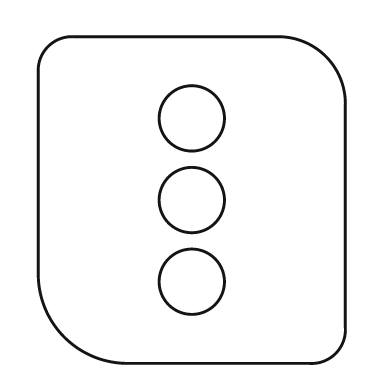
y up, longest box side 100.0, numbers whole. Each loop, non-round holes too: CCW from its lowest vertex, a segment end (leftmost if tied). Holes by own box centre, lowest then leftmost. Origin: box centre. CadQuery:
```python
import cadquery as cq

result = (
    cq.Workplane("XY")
    .moveTo(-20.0, -50.0)
    .lineTo(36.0, -50.0)
    .threePointArc((44.0, -47.0), (47.0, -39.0))
    .lineTo(47.0, 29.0)
    .threePointArc((41.0, 44.0), (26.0, 50.0))
    .lineTo(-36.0, 50.0)
    .threePointArc((-44.0, 47.0), (-47.0, 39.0))
    .lineTo(-47.0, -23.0)
    .threePointArc((-39.0, -42.0), (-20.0, -50.0))
    .close()
    .moveTo(0.0, -25.0)
    .circle(10.0)
    .moveTo(0.0, 0.0)
    .circle(10.0)
    .moveTo(0.0, 25.0)
    .circle(10.0)
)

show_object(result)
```